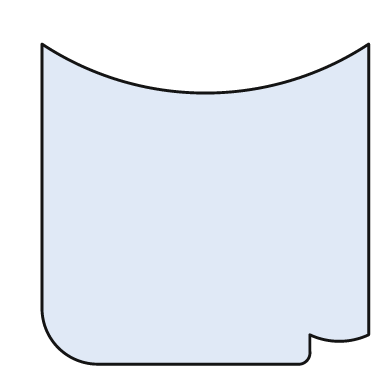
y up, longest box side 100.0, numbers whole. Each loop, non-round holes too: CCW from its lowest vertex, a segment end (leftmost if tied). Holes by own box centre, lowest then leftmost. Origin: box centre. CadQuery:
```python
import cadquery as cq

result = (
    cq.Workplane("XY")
    .moveTo(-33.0, -49.0)
    .lineTo(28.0, -49.0)
    .threePointArc((31.0, -48.0), (32.0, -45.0))
    .lineTo(32.0, -40.0)
    .threePointArc((41.0, -42.0), (50.0, -40.0))
    .lineTo(50.0, 49.0)
    .threePointArc((0.0, 34.0), (-50.0, 49.0))
    .lineTo(-50.0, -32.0)
    .threePointArc((-45.0, -44.0), (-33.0, -49.0))
    .close()
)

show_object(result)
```